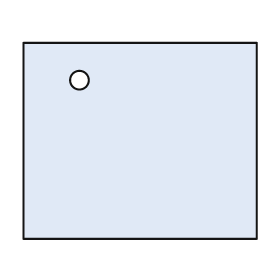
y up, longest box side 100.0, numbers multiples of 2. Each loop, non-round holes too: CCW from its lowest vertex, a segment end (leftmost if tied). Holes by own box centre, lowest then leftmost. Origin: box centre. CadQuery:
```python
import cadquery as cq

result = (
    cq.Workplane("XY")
    .moveTo(-50.0, -42.0)
    .lineTo(50.0, -42.0)
    .lineTo(50.0, 42.0)
    .lineTo(-50.0, 42.0)
    .close()
    .moveTo(-26.0, 26.0)
    .circle(4.0)
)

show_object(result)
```